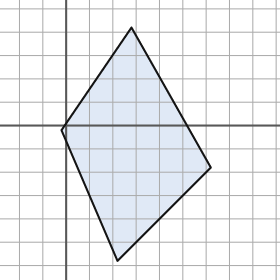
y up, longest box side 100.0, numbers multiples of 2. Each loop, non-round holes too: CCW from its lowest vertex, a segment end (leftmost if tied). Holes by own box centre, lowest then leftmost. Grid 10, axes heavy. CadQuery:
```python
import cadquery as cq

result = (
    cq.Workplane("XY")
    .moveTo(22.0, -58.0)
    .lineTo(62.0, -18.0)
    .lineTo(28.0, 42.0)
    .lineTo(-2.0, -2.0)
    .close()
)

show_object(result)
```